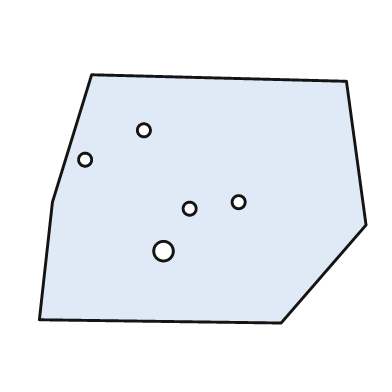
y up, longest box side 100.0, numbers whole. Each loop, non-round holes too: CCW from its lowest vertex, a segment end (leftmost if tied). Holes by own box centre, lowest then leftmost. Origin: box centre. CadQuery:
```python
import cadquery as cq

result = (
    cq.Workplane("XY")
    .moveTo(24.0, -38.0)
    .lineTo(50.0, -8.0)
    .lineTo(44.0, 36.0)
    .lineTo(-34.0, 38.0)
    .lineTo(-46.0, -1.0)
    .lineTo(-50.0, -37.0)
    .close()
    .moveTo(-12.0, -16.0)
    .circle(3.0)
    .moveTo(-4.0, -3.0)
    .circle(2.0)
    .moveTo(11.0, -1.0)
    .circle(2.0)
    .moveTo(-36.0, 12.0)
    .circle(2.0)
    .moveTo(-18.0, 21.0)
    .circle(2.0)
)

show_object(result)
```